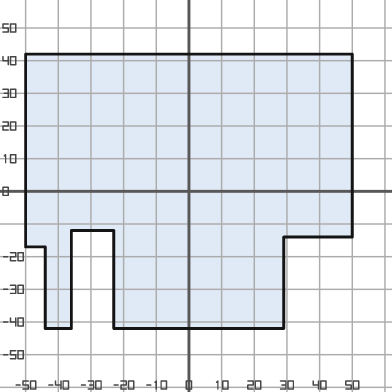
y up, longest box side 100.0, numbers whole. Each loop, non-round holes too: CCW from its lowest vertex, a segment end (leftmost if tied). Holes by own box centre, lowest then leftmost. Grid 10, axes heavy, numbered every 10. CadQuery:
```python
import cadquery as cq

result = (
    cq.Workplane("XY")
    .moveTo(-44.0, -42.0)
    .lineTo(-36.0, -42.0)
    .lineTo(-36.0, -12.0)
    .lineTo(-23.0, -12.0)
    .lineTo(-23.0, -42.0)
    .lineTo(29.0, -42.0)
    .lineTo(29.0, -14.0)
    .lineTo(50.0, -14.0)
    .lineTo(50.0, 42.0)
    .lineTo(-50.0, 42.0)
    .lineTo(-50.0, -17.0)
    .lineTo(-44.0, -17.0)
    .close()
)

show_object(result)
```